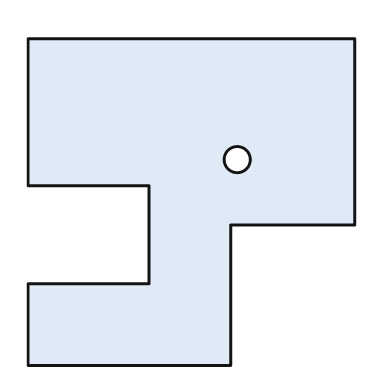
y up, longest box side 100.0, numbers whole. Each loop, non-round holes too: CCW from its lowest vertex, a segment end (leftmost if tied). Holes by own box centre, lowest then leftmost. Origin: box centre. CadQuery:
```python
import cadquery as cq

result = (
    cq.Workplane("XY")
    .moveTo(-50.0, -50.0)
    .lineTo(12.0, -50.0)
    .lineTo(12.0, -7.0)
    .lineTo(50.0, -7.0)
    .lineTo(50.0, 50.0)
    .lineTo(-50.0, 50.0)
    .lineTo(-50.0, 5.0)
    .lineTo(-13.0, 5.0)
    .lineTo(-13.0, -25.0)
    .lineTo(-50.0, -25.0)
    .close()
    .moveTo(14.0, 13.0)
    .circle(4.0)
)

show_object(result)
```